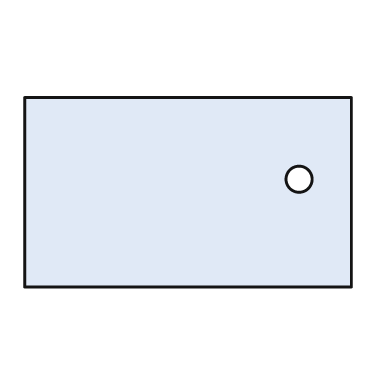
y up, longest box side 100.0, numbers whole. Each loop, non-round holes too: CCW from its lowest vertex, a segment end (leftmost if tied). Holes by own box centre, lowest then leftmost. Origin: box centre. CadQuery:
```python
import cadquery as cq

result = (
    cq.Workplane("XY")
    .moveTo(-50.0, -29.0)
    .lineTo(50.0, -29.0)
    .lineTo(50.0, 29.0)
    .lineTo(-50.0, 29.0)
    .close()
    .moveTo(34.0, 4.0)
    .circle(4.0)
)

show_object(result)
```